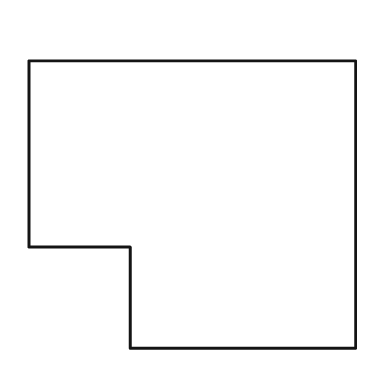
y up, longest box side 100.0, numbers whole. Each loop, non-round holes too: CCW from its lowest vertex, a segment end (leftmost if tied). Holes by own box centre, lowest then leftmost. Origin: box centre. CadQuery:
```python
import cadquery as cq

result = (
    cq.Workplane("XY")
    .moveTo(-19.0, -44.0)
    .lineTo(50.0, -44.0)
    .lineTo(50.0, 44.0)
    .lineTo(-50.0, 44.0)
    .lineTo(-50.0, -13.0)
    .lineTo(-19.0, -13.0)
    .close()
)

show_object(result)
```